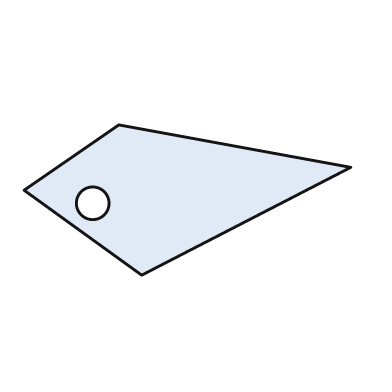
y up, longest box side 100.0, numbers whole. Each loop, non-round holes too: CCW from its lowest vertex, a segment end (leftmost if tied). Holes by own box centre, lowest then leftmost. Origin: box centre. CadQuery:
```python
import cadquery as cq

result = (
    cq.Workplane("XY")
    .moveTo(-14.0, -23.0)
    .lineTo(50.0, 10.0)
    .lineTo(-21.0, 23.0)
    .lineTo(-50.0, 3.0)
    .close()
    .moveTo(-29.0, -1.0)
    .circle(5.0)
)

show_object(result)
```